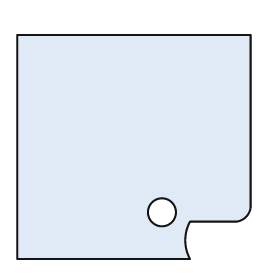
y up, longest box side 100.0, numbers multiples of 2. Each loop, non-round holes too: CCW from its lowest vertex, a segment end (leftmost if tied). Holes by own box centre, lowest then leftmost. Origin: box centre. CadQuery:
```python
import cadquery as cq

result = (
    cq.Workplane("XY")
    .moveTo(-50.0, -48.0)
    .lineTo(24.0, -48.0)
    .threePointArc((22.0, -40.0), (24.0, -32.0))
    .lineTo(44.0, -32.0)
    .threePointArc((48.0, -30.0), (50.0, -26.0))
    .lineTo(50.0, 48.0)
    .lineTo(-50.0, 48.0)
    .close()
    .moveTo(12.0, -28.0)
    .circle(6.0)
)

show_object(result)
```